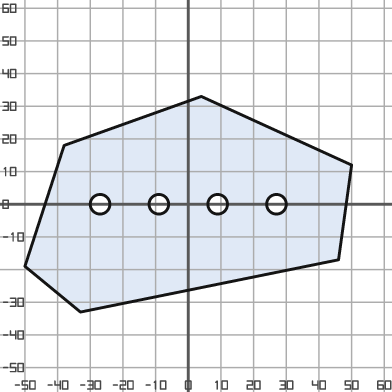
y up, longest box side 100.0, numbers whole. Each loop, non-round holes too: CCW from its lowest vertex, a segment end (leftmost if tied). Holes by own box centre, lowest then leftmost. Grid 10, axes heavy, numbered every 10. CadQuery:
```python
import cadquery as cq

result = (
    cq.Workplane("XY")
    .moveTo(-33.0, -33.0)
    .lineTo(46.0, -17.0)
    .lineTo(50.0, 12.0)
    .lineTo(4.0, 33.0)
    .lineTo(-38.0, 18.0)
    .lineTo(-50.0, -19.0)
    .close()
    .moveTo(-27.0, 0.0)
    .circle(3.0)
    .moveTo(-9.0, 0.0)
    .circle(3.0)
    .moveTo(9.0, 0.0)
    .circle(3.0)
    .moveTo(27.0, 0.0)
    .circle(3.0)
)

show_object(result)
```